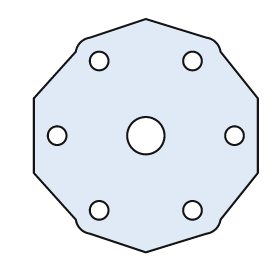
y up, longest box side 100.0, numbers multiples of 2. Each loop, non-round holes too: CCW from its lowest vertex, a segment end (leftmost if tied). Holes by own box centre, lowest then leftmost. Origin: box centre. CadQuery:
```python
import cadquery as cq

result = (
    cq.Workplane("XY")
    .moveTo(0.0, -50.0)
    .lineTo(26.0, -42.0)
    .threePointArc((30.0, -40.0), (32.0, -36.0))
    .lineTo(48.0, -16.0)
    .lineTo(48.0, 16.0)
    .lineTo(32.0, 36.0)
    .threePointArc((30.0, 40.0), (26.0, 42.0))
    .lineTo(0.0, 50.0)
    .lineTo(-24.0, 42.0)
    .threePointArc((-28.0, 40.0), (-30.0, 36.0))
    .lineTo(-48.0, 16.0)
    .lineTo(-48.0, -16.0)
    .lineTo(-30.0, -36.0)
    .threePointArc((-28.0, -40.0), (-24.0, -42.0))
    .close()
    .moveTo(-20.0, -32.0)
    .circle(4.0)
    .moveTo(20.0, -32.0)
    .circle(4.0)
    .moveTo(-38.0, 0.0)
    .circle(4.0)
    .moveTo(0.0, 0.0)
    .circle(8.0)
    .moveTo(38.0, 0.0)
    .circle(4.0)
    .moveTo(-20.0, 32.0)
    .circle(4.0)
    .moveTo(20.0, 32.0)
    .circle(4.0)
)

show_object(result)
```